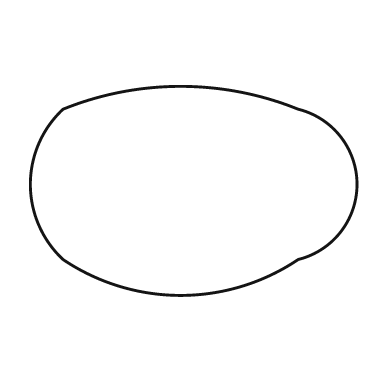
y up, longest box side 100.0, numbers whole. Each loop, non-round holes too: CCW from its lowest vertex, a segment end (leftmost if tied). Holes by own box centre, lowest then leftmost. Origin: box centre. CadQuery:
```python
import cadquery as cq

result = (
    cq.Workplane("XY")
    .moveTo(-40.0, -21.0)
    .threePointArc((-4.0, -32.0), (32.0, -21.0))
    .threePointArc((50.0, 2.0), (32.0, 25.0))
    .threePointArc((-4.0, 32.0), (-40.0, 25.0))
    .threePointArc((-50.0, 2.0), (-40.0, -21.0))
    .close()
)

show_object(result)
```